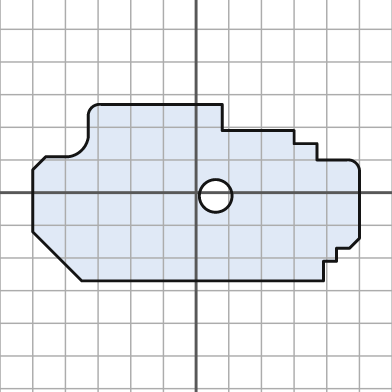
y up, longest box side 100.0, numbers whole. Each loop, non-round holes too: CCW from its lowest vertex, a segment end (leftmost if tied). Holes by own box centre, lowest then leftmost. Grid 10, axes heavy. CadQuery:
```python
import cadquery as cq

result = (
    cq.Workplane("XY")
    .moveTo(-35.0, -27.0)
    .lineTo(39.0, -27.0)
    .lineTo(39.0, -21.0)
    .lineTo(43.0, -21.0)
    .lineTo(43.0, -17.0)
    .lineTo(47.0, -17.0)
    .lineTo(50.0, -14.0)
    .lineTo(50.0, 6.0)
    .threePointArc((49.0, 9.0), (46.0, 10.0))
    .lineTo(37.0, 10.0)
    .lineTo(37.0, 15.0)
    .lineTo(30.0, 15.0)
    .lineTo(30.0, 19.0)
    .lineTo(8.0, 19.0)
    .lineTo(8.0, 27.0)
    .lineTo(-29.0, 27.0)
    .threePointArc((-32.0, 26.0), (-33.0, 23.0))
    .lineTo(-33.0, 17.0)
    .threePointArc((-35.0, 13.0), (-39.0, 11.0))
    .lineTo(-46.0, 11.0)
    .lineTo(-50.0, 7.0)
    .lineTo(-50.0, -12.0)
    .close()
    .moveTo(6.0, -1.0)
    .circle(5.0)
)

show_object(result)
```